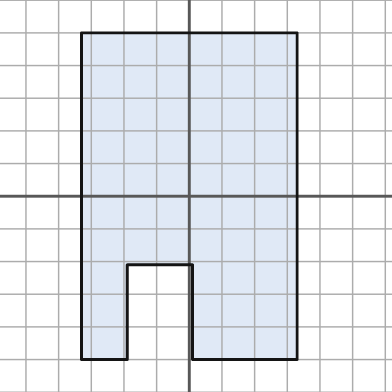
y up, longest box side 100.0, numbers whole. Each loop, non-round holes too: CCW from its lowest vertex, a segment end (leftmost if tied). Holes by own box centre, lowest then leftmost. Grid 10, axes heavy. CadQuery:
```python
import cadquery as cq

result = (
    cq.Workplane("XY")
    .moveTo(-33.0, -50.0)
    .lineTo(-19.0, -50.0)
    .lineTo(-19.0, -21.0)
    .lineTo(1.0, -21.0)
    .lineTo(1.0, -50.0)
    .lineTo(33.0, -50.0)
    .lineTo(33.0, 50.0)
    .lineTo(-33.0, 50.0)
    .close()
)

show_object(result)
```